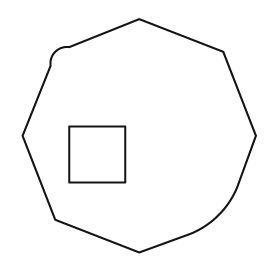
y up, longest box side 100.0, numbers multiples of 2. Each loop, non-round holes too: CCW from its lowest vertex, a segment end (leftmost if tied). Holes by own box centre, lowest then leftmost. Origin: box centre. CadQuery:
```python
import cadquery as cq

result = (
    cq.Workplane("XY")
    .moveTo(0.0, -50.0)
    .lineTo(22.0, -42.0)
    .threePointArc((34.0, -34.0), (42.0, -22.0))
    .lineTo(50.0, 0.0)
    .lineTo(36.0, 36.0)
    .lineTo(0.0, 50.0)
    .lineTo(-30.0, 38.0)
    .threePointArc((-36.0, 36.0), (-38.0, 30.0))
    .lineTo(-50.0, 0.0)
    .lineTo(-36.0, -36.0)
    .close()
    .moveTo(-30.0, -20.0)
    .lineTo(-6.0, -20.0)
    .lineTo(-6.0, 4.0)
    .lineTo(-30.0, 4.0)
    .close()
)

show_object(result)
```